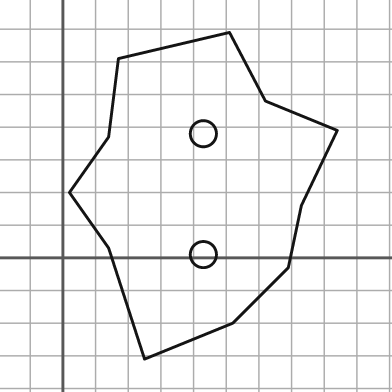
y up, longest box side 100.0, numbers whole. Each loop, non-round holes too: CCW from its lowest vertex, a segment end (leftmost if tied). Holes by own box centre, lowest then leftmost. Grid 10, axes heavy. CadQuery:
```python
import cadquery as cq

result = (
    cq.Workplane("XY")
    .moveTo(25.0, -31.0)
    .lineTo(52.0, -20.0)
    .lineTo(69.0, -3.0)
    .lineTo(73.0, 16.0)
    .lineTo(84.0, 39.0)
    .lineTo(62.0, 48.0)
    .lineTo(51.0, 69.0)
    .lineTo(17.0, 61.0)
    .lineTo(14.0, 37.0)
    .lineTo(2.0, 20.0)
    .lineTo(14.0, 3.0)
    .close()
    .moveTo(43.0, 1.0)
    .circle(4.0)
    .moveTo(43.0, 38.0)
    .circle(4.0)
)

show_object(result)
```